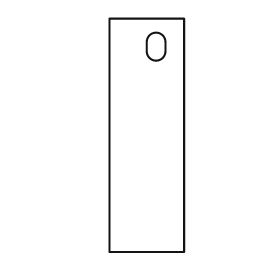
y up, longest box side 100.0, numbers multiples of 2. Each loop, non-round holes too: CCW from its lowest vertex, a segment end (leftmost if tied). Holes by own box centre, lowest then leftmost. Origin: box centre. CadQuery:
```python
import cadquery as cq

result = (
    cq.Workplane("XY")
    .moveTo(-16.0, -50.0)
    .lineTo(16.0, -50.0)
    .lineTo(16.0, 50.0)
    .lineTo(-16.0, 50.0)
    .close()
    .moveTo(0.0, 36.0)
    .threePointArc((4.0, 32.0), (8.0, 36.0))
    .lineTo(8.0, 40.0)
    .threePointArc((4.0, 44.0), (0.0, 40.0))
    .close()
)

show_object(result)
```